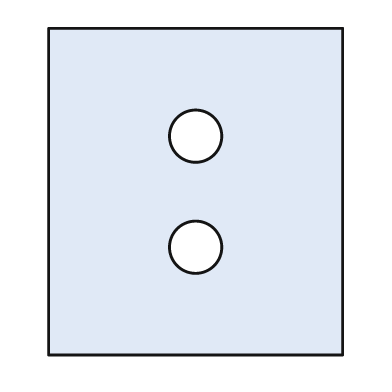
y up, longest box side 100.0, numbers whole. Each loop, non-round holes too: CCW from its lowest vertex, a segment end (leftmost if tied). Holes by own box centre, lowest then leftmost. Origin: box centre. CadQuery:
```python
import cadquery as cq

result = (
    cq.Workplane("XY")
    .moveTo(-45.0, -50.0)
    .lineTo(45.0, -50.0)
    .lineTo(45.0, 50.0)
    .lineTo(-45.0, 50.0)
    .close()
    .moveTo(0.0, -17.0)
    .circle(8.0)
    .moveTo(0.0, 17.0)
    .circle(8.0)
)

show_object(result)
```